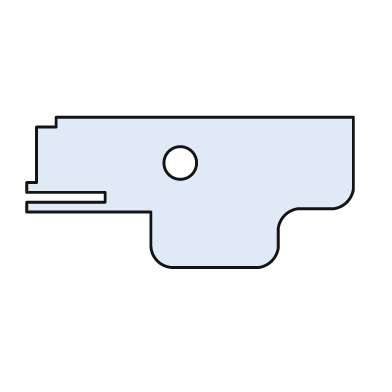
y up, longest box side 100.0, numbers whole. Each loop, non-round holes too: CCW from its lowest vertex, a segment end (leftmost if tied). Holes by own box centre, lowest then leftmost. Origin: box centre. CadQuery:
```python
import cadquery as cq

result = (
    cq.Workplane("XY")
    .moveTo(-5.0, -23.0)
    .lineTo(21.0, -23.0)
    .threePointArc((25.0, -21.0), (27.0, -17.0))
    .lineTo(27.0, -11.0)
    .threePointArc((29.0, -7.0), (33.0, -5.0))
    .lineTo(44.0, -5.0)
    .threePointArc((48.0, -3.0), (50.0, 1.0))
    .lineTo(50.0, 23.0)
    .lineTo(-41.0, 23.0)
    .lineTo(-41.0, 20.0)
    .lineTo(-47.0, 20.0)
    .lineTo(-47.0, 3.0)
    .lineTo(-50.0, 3.0)
    .lineTo(-50.0, 0.0)
    .lineTo(-26.0, 0.0)
    .lineTo(-26.0, -3.0)
    .lineTo(-50.0, -3.0)
    .lineTo(-50.0, -6.0)
    .lineTo(-12.0, -6.0)
    .lineTo(-12.0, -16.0)
    .threePointArc((-10.0, -21.0), (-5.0, -23.0))
    .close()
    .moveTo(-3.0, 9.0)
    .circle(5.0)
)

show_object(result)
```